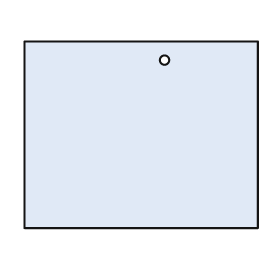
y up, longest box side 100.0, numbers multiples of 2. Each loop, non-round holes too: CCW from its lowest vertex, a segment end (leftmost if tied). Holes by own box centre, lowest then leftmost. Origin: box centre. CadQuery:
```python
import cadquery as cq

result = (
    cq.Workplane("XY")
    .moveTo(-50.0, -40.0)
    .lineTo(50.0, -40.0)
    .lineTo(50.0, 40.0)
    .lineTo(-50.0, 40.0)
    .close()
    .moveTo(10.0, 32.0)
    .circle(2.0)
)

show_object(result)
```